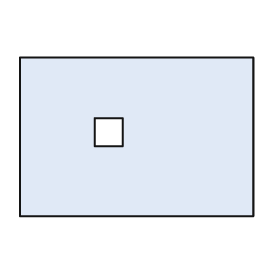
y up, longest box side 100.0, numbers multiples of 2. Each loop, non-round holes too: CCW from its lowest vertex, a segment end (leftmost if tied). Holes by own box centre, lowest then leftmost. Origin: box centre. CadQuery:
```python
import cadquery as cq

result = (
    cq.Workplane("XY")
    .moveTo(-50.0, -34.0)
    .lineTo(50.0, -34.0)
    .lineTo(50.0, 34.0)
    .lineTo(-50.0, 34.0)
    .close()
    .moveTo(-18.0, -4.0)
    .lineTo(-6.0, -4.0)
    .lineTo(-6.0, 8.0)
    .lineTo(-18.0, 8.0)
    .close()
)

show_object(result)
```